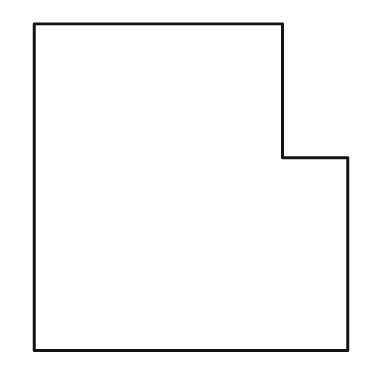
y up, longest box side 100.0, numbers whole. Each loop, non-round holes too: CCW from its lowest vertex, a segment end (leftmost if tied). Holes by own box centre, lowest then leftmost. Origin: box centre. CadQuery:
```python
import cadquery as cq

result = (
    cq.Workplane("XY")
    .moveTo(-48.0, -50.0)
    .lineTo(48.0, -50.0)
    .lineTo(48.0, 9.0)
    .lineTo(28.0, 9.0)
    .lineTo(28.0, 50.0)
    .lineTo(-48.0, 50.0)
    .close()
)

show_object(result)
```